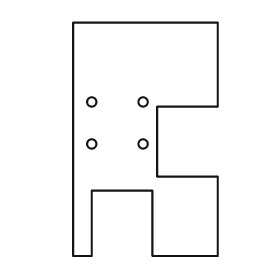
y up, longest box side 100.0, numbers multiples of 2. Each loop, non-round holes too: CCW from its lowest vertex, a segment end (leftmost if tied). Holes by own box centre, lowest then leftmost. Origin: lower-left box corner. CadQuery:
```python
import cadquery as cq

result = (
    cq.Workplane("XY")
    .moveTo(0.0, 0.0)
    .lineTo(8.0, 0.0)
    .lineTo(8.0, 28.0)
    .lineTo(34.0, 28.0)
    .lineTo(34.0, 0.0)
    .lineTo(62.0, 0.0)
    .lineTo(62.0, 34.0)
    .lineTo(36.0, 34.0)
    .lineTo(36.0, 64.0)
    .lineTo(62.0, 64.0)
    .lineTo(62.0, 100.0)
    .lineTo(0.0, 100.0)
    .close()
    .moveTo(8.0, 48.0)
    .circle(2.0)
    .moveTo(30.0, 48.0)
    .circle(2.0)
    .moveTo(8.0, 66.0)
    .circle(2.0)
    .moveTo(30.0, 66.0)
    .circle(2.0)
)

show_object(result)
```